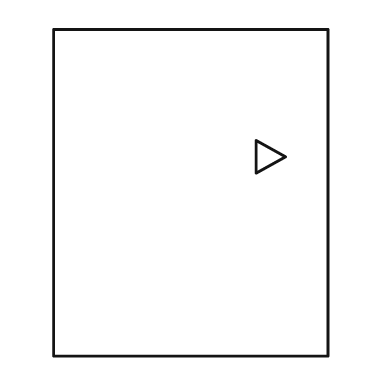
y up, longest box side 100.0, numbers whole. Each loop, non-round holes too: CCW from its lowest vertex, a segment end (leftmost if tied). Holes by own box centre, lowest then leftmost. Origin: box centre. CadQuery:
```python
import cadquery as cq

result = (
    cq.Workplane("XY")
    .moveTo(-42.0, -50.0)
    .lineTo(42.0, -50.0)
    .lineTo(42.0, 50.0)
    .lineTo(-42.0, 50.0)
    .close()
    .moveTo(20.0, 6.0)
    .lineTo(29.0, 11.0)
    .lineTo(20.0, 16.0)
    .close()
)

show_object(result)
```